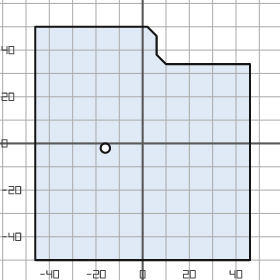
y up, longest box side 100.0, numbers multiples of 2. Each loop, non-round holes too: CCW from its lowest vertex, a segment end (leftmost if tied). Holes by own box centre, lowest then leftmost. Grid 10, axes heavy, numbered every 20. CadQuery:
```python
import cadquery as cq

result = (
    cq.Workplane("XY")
    .moveTo(-46.0, -50.0)
    .lineTo(46.0, -50.0)
    .lineTo(46.0, 34.0)
    .lineTo(10.0, 34.0)
    .lineTo(6.0, 38.0)
    .lineTo(6.0, 46.0)
    .lineTo(2.0, 50.0)
    .lineTo(-46.0, 50.0)
    .close()
    .moveTo(-16.0, -2.0)
    .circle(2.0)
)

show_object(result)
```